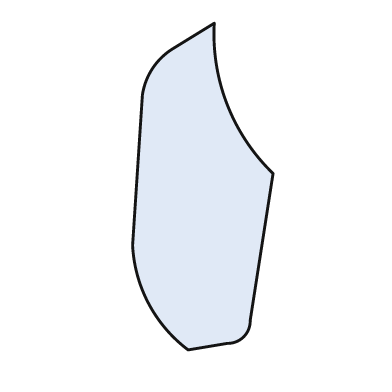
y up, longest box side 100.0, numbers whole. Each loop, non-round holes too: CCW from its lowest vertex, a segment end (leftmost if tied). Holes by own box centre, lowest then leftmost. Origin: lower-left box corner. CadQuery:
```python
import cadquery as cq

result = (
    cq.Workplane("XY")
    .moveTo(17.0, 0.0)
    .lineTo(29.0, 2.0)
    .threePointArc((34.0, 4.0), (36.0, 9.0))
    .lineTo(43.0, 54.0)
    .threePointArc((29.0, 75.0), (25.0, 100.0))
    .lineTo(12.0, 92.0)
    .threePointArc((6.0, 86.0), (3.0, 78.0))
    .lineTo(0.0, 32.0)
    .threePointArc((5.0, 14.0), (17.0, 0.0))
    .close()
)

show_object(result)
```